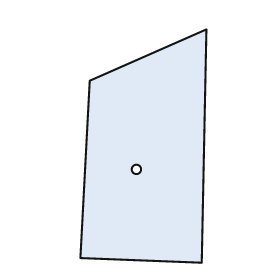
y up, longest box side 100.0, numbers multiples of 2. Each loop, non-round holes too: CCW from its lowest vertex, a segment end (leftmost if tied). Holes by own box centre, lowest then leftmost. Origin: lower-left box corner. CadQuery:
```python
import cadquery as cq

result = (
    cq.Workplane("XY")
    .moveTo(52.0, 0.0)
    .lineTo(54.0, 100.0)
    .lineTo(4.0, 78.0)
    .lineTo(0.0, 2.0)
    .close()
    .moveTo(24.0, 40.0)
    .circle(2.0)
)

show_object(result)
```